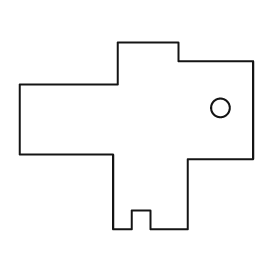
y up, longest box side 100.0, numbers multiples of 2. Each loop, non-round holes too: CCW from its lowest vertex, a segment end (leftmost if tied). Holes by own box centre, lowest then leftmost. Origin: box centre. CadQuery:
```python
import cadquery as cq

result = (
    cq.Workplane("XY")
    .moveTo(-10.0, -40.0)
    .lineTo(-2.0, -40.0)
    .lineTo(-2.0, -32.0)
    .lineTo(6.0, -32.0)
    .lineTo(6.0, -40.0)
    .lineTo(22.0, -40.0)
    .lineTo(22.0, -10.0)
    .lineTo(50.0, -10.0)
    .lineTo(50.0, 32.0)
    .lineTo(18.0, 32.0)
    .lineTo(18.0, 40.0)
    .lineTo(-8.0, 40.0)
    .lineTo(-8.0, 22.0)
    .lineTo(-50.0, 22.0)
    .lineTo(-50.0, -8.0)
    .lineTo(-10.0, -8.0)
    .close()
    .moveTo(36.0, 12.0)
    .circle(4.0)
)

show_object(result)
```